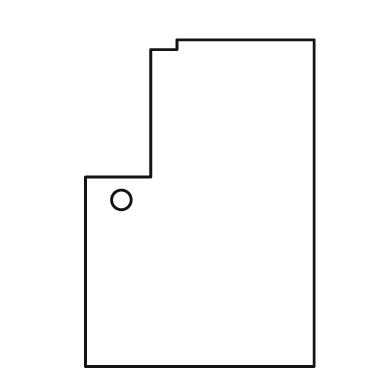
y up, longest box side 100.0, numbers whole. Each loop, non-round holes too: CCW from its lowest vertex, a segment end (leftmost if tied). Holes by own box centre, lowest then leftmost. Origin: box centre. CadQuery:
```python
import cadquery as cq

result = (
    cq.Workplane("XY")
    .moveTo(-35.0, -50.0)
    .lineTo(35.0, -50.0)
    .lineTo(35.0, 50.0)
    .lineTo(-7.0, 50.0)
    .lineTo(-7.0, 47.0)
    .lineTo(-15.0, 47.0)
    .lineTo(-15.0, 8.0)
    .lineTo(-35.0, 8.0)
    .close()
    .moveTo(-24.0, 1.0)
    .circle(3.0)
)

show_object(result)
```